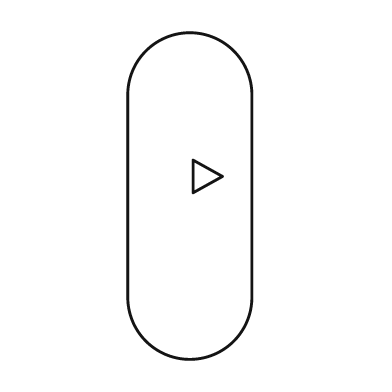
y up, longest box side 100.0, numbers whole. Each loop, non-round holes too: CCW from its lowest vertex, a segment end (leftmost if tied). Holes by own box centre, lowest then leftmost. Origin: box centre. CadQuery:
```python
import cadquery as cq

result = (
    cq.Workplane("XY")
    .moveTo(-19.0, -31.0)
    .threePointArc((0.0, -50.0), (19.0, -31.0))
    .lineTo(19.0, 31.0)
    .threePointArc((0.0, 50.0), (-19.0, 31.0))
    .close()
    .moveTo(1.0, 1.0)
    .lineTo(10.0, 6.0)
    .lineTo(1.0, 11.0)
    .close()
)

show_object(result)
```